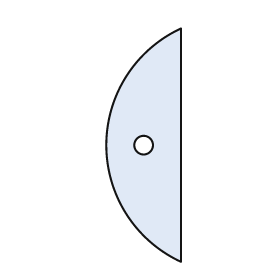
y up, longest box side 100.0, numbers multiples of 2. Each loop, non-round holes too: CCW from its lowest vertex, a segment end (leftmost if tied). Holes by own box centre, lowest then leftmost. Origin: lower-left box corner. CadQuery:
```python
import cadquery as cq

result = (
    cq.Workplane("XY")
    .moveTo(32.0, 0.0)
    .lineTo(32.0, 100.0)
    .threePointArc((0.0, 50.0), (32.0, 0.0))
    .close()
    .moveTo(16.0, 50.0)
    .circle(4.0)
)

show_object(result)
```